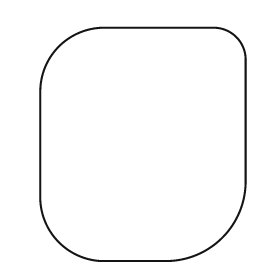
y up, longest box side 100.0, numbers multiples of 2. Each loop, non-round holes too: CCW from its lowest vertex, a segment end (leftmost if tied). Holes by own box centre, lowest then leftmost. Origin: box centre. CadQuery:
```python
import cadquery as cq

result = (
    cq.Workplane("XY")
    .moveTo(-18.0, -50.0)
    .lineTo(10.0, -50.0)
    .threePointArc((34.0, -40.0), (44.0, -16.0))
    .lineTo(44.0, 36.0)
    .threePointArc((40.0, 46.0), (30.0, 50.0))
    .lineTo(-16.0, 50.0)
    .threePointArc((-36.0, 42.0), (-44.0, 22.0))
    .lineTo(-44.0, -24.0)
    .threePointArc((-36.0, -42.0), (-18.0, -50.0))
    .close()
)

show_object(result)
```